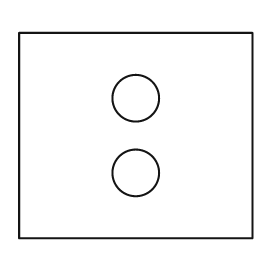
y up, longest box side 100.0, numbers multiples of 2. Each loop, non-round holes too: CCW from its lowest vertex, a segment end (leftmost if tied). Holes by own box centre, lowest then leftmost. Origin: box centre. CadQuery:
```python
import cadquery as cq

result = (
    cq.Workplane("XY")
    .moveTo(-50.0, -44.0)
    .lineTo(50.0, -44.0)
    .lineTo(50.0, 44.0)
    .lineTo(-50.0, 44.0)
    .close()
    .moveTo(0.0, -16.0)
    .circle(10.0)
    .moveTo(0.0, 16.0)
    .circle(10.0)
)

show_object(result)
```